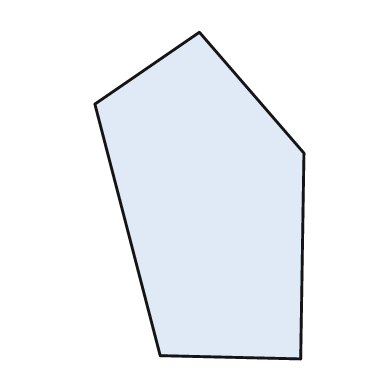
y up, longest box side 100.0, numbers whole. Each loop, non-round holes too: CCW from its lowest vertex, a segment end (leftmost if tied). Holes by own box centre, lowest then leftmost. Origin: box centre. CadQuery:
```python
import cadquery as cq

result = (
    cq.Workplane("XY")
    .moveTo(31.0, -50.0)
    .lineTo(32.0, 13.0)
    .lineTo(0.0, 50.0)
    .lineTo(-32.0, 28.0)
    .lineTo(-12.0, -49.0)
    .close()
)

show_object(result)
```